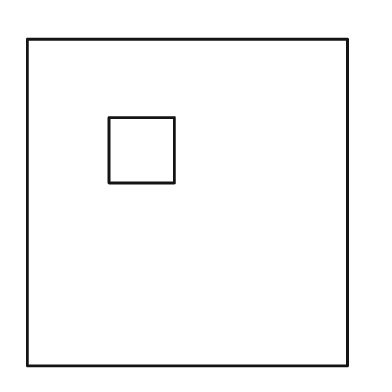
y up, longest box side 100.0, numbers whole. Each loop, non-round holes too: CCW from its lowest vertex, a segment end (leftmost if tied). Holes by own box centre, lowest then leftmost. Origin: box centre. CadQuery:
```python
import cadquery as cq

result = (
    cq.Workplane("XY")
    .moveTo(-49.0, -50.0)
    .lineTo(49.0, -50.0)
    .lineTo(49.0, 50.0)
    .lineTo(-49.0, 50.0)
    .close()
    .moveTo(-24.0, 6.0)
    .lineTo(-4.0, 6.0)
    .lineTo(-4.0, 26.0)
    .lineTo(-24.0, 26.0)
    .close()
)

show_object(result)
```